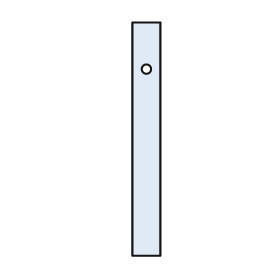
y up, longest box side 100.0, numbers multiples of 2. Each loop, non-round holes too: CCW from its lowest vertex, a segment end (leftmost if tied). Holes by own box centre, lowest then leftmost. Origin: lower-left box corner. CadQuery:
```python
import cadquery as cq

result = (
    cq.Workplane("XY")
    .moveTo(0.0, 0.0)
    .lineTo(12.0, 0.0)
    .lineTo(12.0, 100.0)
    .lineTo(0.0, 100.0)
    .close()
    .moveTo(6.0, 80.0)
    .circle(2.0)
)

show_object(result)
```